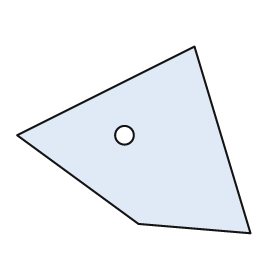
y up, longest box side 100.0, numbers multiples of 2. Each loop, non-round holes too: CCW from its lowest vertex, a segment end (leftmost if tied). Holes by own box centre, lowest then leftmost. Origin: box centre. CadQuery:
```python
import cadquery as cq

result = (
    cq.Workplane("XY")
    .moveTo(50.0, -40.0)
    .lineTo(26.0, 40.0)
    .lineTo(-50.0, 2.0)
    .lineTo(2.0, -36.0)
    .close()
    .moveTo(-4.0, 2.0)
    .circle(4.0)
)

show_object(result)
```